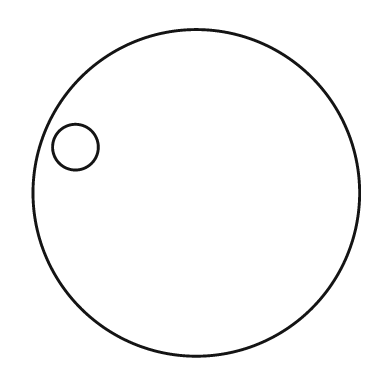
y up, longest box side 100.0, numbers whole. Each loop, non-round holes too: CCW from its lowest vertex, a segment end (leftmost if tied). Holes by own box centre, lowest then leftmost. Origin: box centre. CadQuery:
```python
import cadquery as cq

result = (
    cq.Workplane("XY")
    .moveTo(0.0, 0.0)
    .circle(50.0)
    .moveTo(-37.0, 14.0)
    .circle(7.0)
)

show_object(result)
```